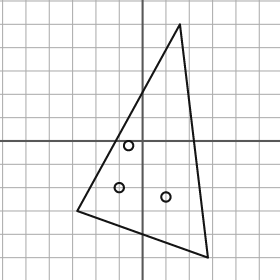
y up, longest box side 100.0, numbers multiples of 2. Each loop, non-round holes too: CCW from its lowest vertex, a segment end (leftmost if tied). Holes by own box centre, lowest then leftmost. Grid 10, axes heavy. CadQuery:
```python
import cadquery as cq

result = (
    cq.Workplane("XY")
    .moveTo(28.0, -50.0)
    .lineTo(16.0, 50.0)
    .lineTo(-28.0, -30.0)
    .close()
    .moveTo(10.0, -24.0)
    .circle(2.0)
    .moveTo(-10.0, -20.0)
    .circle(2.0)
    .moveTo(-6.0, -2.0)
    .circle(2.0)
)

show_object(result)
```